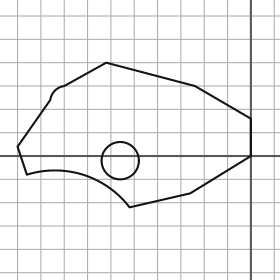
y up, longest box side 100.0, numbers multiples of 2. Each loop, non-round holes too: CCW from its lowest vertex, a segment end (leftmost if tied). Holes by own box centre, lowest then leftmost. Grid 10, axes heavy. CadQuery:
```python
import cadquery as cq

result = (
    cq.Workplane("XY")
    .moveTo(-52.0, -22.0)
    .lineTo(-26.0, -16.0)
    .lineTo(0.0, 0.0)
    .lineTo(0.0, 16.0)
    .lineTo(-24.0, 30.0)
    .lineTo(-62.0, 40.0)
    .lineTo(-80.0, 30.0)
    .threePointArc((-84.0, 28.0), (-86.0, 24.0))
    .lineTo(-100.0, 4.0)
    .lineTo(-96.0, -8.0)
    .threePointArc((-72.0, -8.0), (-52.0, -22.0))
    .close()
    .moveTo(-56.0, -2.0)
    .circle(8.0)
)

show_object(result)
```